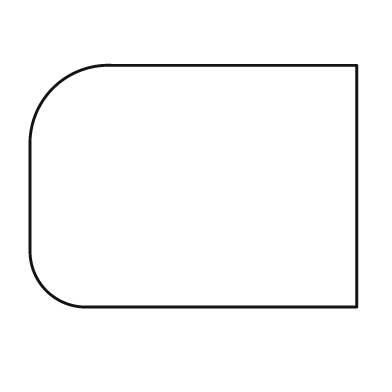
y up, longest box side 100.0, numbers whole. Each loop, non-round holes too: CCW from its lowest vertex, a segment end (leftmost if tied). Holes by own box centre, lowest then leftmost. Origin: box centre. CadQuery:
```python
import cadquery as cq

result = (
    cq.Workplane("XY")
    .moveTo(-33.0, -37.0)
    .lineTo(50.0, -37.0)
    .lineTo(50.0, 37.0)
    .lineTo(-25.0, 37.0)
    .threePointArc((-43.0, 30.0), (-50.0, 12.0))
    .lineTo(-50.0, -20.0)
    .threePointArc((-45.0, -32.0), (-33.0, -37.0))
    .close()
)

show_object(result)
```